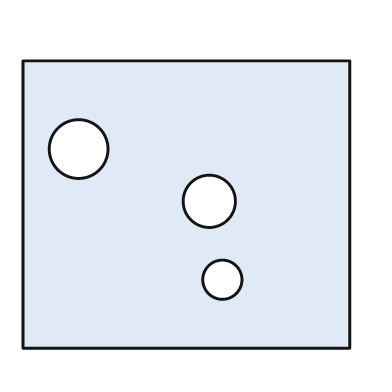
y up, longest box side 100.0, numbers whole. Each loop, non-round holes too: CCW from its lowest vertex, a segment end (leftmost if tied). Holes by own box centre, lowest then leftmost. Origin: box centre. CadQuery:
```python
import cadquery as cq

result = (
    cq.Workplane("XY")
    .moveTo(-50.0, -44.0)
    .lineTo(50.0, -44.0)
    .lineTo(50.0, 44.0)
    .lineTo(-50.0, 44.0)
    .close()
    .moveTo(11.0, -23.0)
    .circle(6.0)
    .moveTo(7.0, 1.0)
    .circle(8.0)
    .moveTo(-33.0, 17.0)
    .circle(9.0)
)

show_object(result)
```